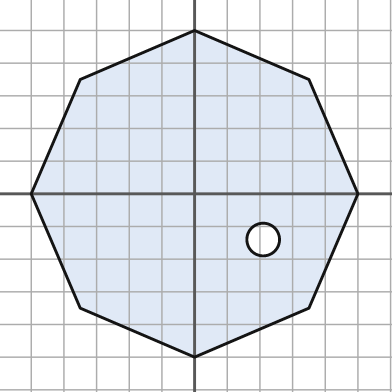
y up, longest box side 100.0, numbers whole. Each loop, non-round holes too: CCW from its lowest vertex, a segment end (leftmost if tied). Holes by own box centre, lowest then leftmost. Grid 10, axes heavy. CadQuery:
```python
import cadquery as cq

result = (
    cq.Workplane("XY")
    .moveTo(0.0, -50.0)
    .lineTo(35.0, -35.0)
    .lineTo(50.0, 0.0)
    .lineTo(35.0, 35.0)
    .lineTo(0.0, 50.0)
    .lineTo(-35.0, 35.0)
    .lineTo(-50.0, 0.0)
    .lineTo(-35.0, -35.0)
    .close()
    .moveTo(21.0, -14.0)
    .circle(5.0)
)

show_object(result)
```